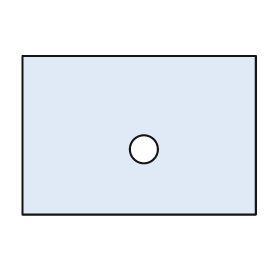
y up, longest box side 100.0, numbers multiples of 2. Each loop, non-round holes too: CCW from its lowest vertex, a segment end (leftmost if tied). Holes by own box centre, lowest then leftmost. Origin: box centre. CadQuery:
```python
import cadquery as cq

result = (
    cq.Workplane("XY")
    .moveTo(-50.0, -34.0)
    .lineTo(50.0, -34.0)
    .lineTo(50.0, 34.0)
    .lineTo(-50.0, 34.0)
    .close()
    .moveTo(2.0, -6.0)
    .circle(6.0)
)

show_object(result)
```